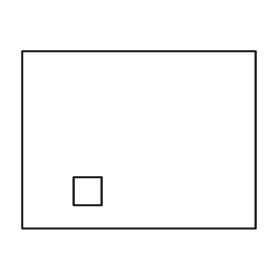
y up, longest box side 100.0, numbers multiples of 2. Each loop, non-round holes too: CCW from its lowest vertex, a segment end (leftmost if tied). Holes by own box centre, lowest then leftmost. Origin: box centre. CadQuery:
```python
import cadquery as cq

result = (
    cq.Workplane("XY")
    .moveTo(-50.0, -38.0)
    .lineTo(50.0, -38.0)
    .lineTo(50.0, 38.0)
    .lineTo(-50.0, 38.0)
    .close()
    .moveTo(-28.0, -28.0)
    .lineTo(-16.0, -28.0)
    .lineTo(-16.0, -16.0)
    .lineTo(-28.0, -16.0)
    .close()
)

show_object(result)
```